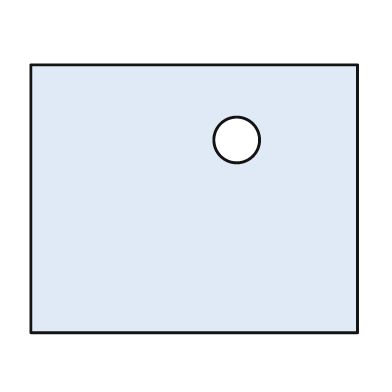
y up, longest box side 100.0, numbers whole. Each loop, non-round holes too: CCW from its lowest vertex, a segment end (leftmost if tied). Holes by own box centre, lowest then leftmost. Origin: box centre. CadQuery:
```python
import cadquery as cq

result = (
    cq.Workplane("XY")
    .moveTo(-50.0, -41.0)
    .lineTo(50.0, -41.0)
    .lineTo(50.0, 41.0)
    .lineTo(-50.0, 41.0)
    .close()
    .moveTo(13.0, 18.0)
    .circle(7.0)
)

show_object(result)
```